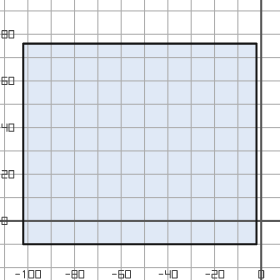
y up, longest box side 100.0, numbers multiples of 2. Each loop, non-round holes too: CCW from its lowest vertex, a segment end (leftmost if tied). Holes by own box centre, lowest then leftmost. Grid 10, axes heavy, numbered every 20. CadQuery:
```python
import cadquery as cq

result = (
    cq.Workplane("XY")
    .moveTo(-102.0, -10.0)
    .lineTo(-2.0, -10.0)
    .lineTo(-2.0, 76.0)
    .lineTo(-102.0, 76.0)
    .close()
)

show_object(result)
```